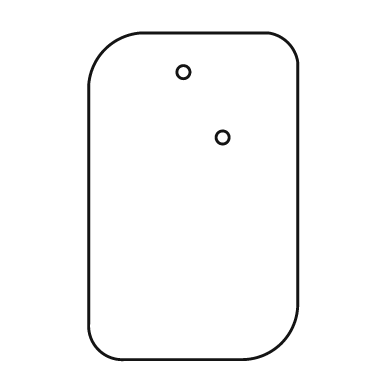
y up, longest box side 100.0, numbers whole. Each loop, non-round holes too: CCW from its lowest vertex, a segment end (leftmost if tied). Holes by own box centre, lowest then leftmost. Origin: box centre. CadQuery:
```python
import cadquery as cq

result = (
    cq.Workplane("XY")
    .moveTo(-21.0, -50.0)
    .lineTo(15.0, -50.0)
    .threePointArc((27.0, -45.0), (32.0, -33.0))
    .lineTo(32.0, 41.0)
    .threePointArc((29.0, 47.0), (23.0, 50.0))
    .lineTo(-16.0, 50.0)
    .threePointArc((-27.0, 45.0), (-32.0, 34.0))
    .lineTo(-32.0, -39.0)
    .threePointArc((-29.0, -47.0), (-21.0, -50.0))
    .close()
    .moveTo(9.0, 18.0)
    .circle(2.0)
    .moveTo(-3.0, 38.0)
    .circle(2.0)
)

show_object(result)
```